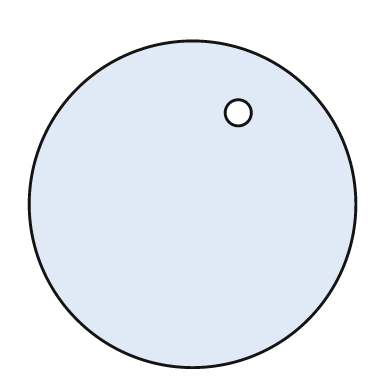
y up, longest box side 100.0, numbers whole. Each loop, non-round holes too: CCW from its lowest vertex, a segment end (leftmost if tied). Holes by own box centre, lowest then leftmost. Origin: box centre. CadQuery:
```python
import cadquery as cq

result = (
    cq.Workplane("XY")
    .moveTo(0.0, 0.0)
    .circle(50.0)
    .moveTo(14.0, 28.0)
    .circle(4.0)
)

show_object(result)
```